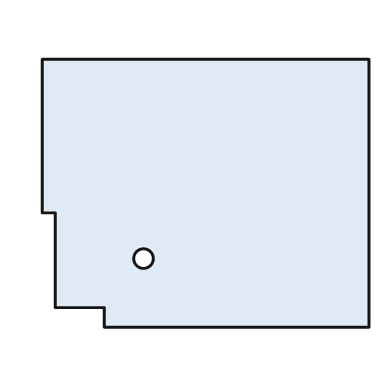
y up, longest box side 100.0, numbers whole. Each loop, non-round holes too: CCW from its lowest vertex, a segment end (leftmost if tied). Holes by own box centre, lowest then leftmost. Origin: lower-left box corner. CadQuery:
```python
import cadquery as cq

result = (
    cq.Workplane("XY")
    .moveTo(19.0, 0.0)
    .lineTo(100.0, 0.0)
    .lineTo(100.0, 82.0)
    .lineTo(0.0, 82.0)
    .lineTo(0.0, 35.0)
    .lineTo(4.0, 35.0)
    .lineTo(4.0, 6.0)
    .lineTo(19.0, 6.0)
    .close()
    .moveTo(31.0, 21.0)
    .circle(3.0)
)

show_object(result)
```